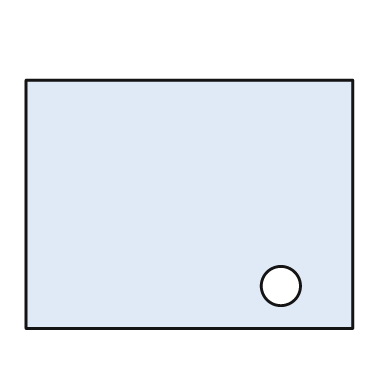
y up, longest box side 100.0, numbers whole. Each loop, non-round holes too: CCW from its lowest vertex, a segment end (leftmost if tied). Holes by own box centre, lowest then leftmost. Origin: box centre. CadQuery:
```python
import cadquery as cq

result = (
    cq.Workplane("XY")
    .moveTo(-50.0, -38.0)
    .lineTo(50.0, -38.0)
    .lineTo(50.0, 38.0)
    .lineTo(-50.0, 38.0)
    .close()
    .moveTo(28.0, -25.0)
    .circle(6.0)
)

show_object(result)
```